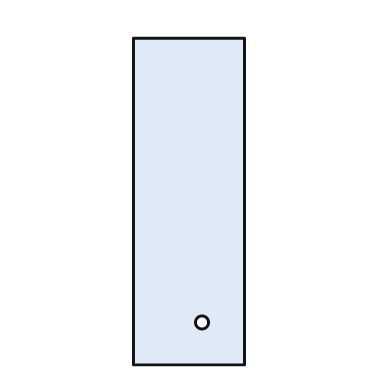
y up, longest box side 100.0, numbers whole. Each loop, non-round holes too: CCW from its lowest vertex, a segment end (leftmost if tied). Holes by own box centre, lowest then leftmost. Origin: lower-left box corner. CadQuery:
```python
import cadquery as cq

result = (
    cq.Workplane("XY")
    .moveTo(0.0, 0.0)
    .lineTo(34.0, 0.0)
    .lineTo(34.0, 100.0)
    .lineTo(0.0, 100.0)
    .close()
    .moveTo(21.0, 13.0)
    .circle(2.0)
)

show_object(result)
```